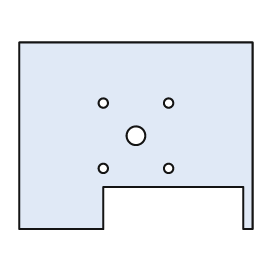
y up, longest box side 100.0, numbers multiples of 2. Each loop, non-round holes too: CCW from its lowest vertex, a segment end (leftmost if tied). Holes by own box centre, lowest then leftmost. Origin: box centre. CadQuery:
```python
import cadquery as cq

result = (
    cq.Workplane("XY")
    .moveTo(-50.0, -40.0)
    .lineTo(-14.0, -40.0)
    .lineTo(-14.0, -22.0)
    .lineTo(46.0, -22.0)
    .lineTo(46.0, -40.0)
    .lineTo(50.0, -40.0)
    .lineTo(50.0, 40.0)
    .lineTo(-50.0, 40.0)
    .close()
    .moveTo(-14.0, -14.0)
    .circle(2.0)
    .moveTo(14.0, -14.0)
    .circle(2.0)
    .moveTo(0.0, 0.0)
    .circle(4.0)
    .moveTo(-14.0, 14.0)
    .circle(2.0)
    .moveTo(14.0, 14.0)
    .circle(2.0)
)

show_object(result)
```